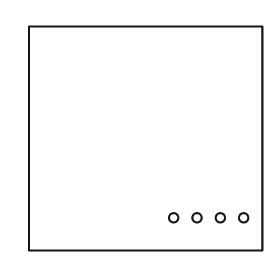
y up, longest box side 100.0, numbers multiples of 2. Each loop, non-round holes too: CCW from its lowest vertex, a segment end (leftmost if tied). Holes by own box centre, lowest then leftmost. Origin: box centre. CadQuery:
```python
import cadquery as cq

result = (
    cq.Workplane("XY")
    .moveTo(-50.0, -48.0)
    .lineTo(50.0, -48.0)
    .lineTo(50.0, 48.0)
    .lineTo(-50.0, 48.0)
    .close()
    .moveTo(12.0, -34.0)
    .circle(2.0)
    .moveTo(22.0, -34.0)
    .circle(2.0)
    .moveTo(32.0, -34.0)
    .circle(2.0)
    .moveTo(42.0, -34.0)
    .circle(2.0)
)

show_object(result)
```